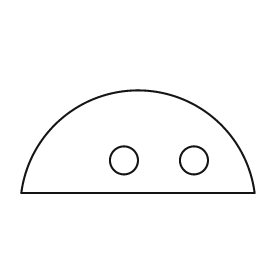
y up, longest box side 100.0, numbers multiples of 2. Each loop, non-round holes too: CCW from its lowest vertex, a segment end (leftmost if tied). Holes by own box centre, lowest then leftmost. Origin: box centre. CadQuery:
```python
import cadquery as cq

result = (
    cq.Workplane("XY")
    .moveTo(-50.0, -22.0)
    .lineTo(50.0, -22.0)
    .threePointArc((0.0, 22.0), (-50.0, -22.0))
    .close()
    .moveTo(-6.0, -8.0)
    .circle(6.0)
    .moveTo(24.0, -8.0)
    .circle(6.0)
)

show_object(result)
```